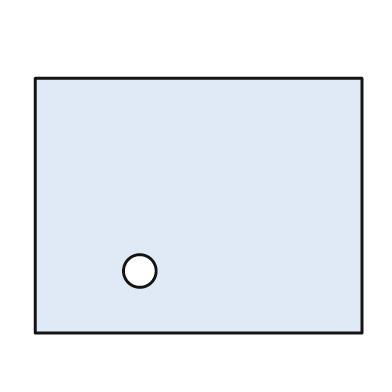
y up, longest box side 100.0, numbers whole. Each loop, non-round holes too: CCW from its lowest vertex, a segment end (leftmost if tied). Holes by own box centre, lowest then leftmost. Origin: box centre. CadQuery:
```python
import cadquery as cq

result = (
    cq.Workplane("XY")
    .moveTo(-50.0, -39.0)
    .lineTo(50.0, -39.0)
    .lineTo(50.0, 39.0)
    .lineTo(-50.0, 39.0)
    .close()
    .moveTo(-18.0, -20.0)
    .circle(5.0)
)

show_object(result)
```